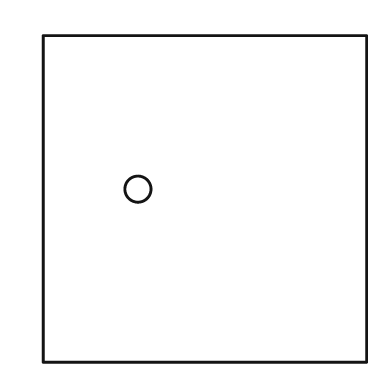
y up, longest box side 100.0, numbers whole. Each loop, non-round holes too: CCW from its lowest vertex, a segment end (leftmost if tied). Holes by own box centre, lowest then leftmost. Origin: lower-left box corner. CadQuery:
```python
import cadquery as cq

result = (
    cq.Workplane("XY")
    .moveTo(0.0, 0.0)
    .lineTo(99.0, 0.0)
    .lineTo(99.0, 100.0)
    .lineTo(0.0, 100.0)
    .close()
    .moveTo(29.0, 53.0)
    .circle(4.0)
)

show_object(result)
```